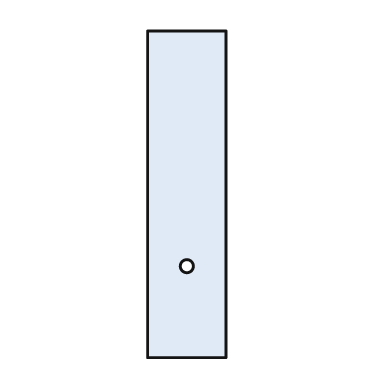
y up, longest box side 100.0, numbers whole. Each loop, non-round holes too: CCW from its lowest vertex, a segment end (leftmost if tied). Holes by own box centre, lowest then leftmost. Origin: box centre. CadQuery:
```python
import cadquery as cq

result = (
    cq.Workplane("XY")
    .moveTo(-12.0, -50.0)
    .lineTo(12.0, -50.0)
    .lineTo(12.0, 50.0)
    .lineTo(-12.0, 50.0)
    .close()
    .moveTo(0.0, -22.0)
    .circle(2.0)
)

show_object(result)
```